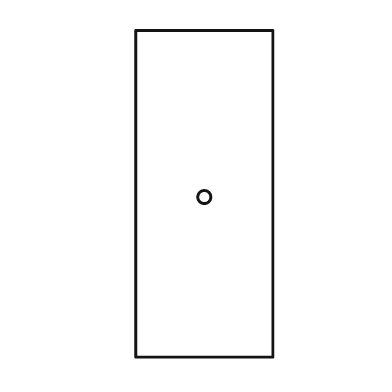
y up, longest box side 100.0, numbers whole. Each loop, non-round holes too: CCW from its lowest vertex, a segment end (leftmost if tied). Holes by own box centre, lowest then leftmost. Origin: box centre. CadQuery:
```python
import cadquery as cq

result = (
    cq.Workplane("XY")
    .moveTo(-21.0, -50.0)
    .lineTo(21.0, -50.0)
    .lineTo(21.0, 50.0)
    .lineTo(-21.0, 50.0)
    .close()
    .moveTo(0.0, -1.0)
    .circle(2.0)
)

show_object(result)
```